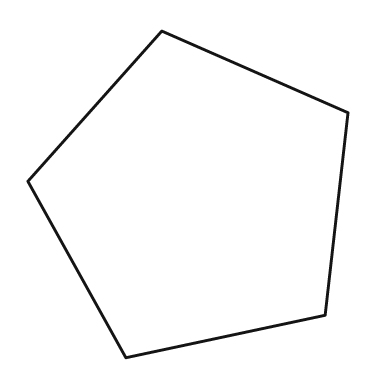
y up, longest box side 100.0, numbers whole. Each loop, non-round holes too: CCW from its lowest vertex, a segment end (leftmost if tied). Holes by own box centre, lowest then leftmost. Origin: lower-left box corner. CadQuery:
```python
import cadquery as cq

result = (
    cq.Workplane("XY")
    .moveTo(30.0, 0.0)
    .lineTo(91.0, 13.0)
    .lineTo(98.0, 75.0)
    .lineTo(41.0, 100.0)
    .lineTo(0.0, 54.0)
    .close()
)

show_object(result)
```